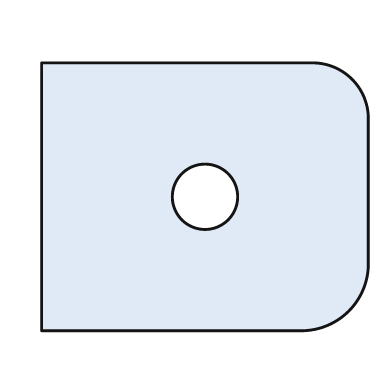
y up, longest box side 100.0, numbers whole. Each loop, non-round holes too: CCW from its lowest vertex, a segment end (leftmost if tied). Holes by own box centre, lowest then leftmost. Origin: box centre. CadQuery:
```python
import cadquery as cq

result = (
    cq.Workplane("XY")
    .moveTo(-50.0, -41.0)
    .lineTo(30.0, -41.0)
    .threePointArc((44.0, -35.0), (50.0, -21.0))
    .lineTo(50.0, 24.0)
    .threePointArc((45.0, 36.0), (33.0, 41.0))
    .lineTo(-50.0, 41.0)
    .close()
    .moveTo(0.0, 0.0)
    .circle(10.0)
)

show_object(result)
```